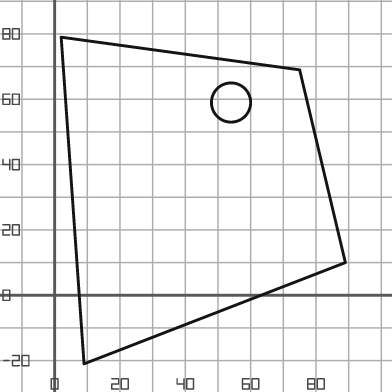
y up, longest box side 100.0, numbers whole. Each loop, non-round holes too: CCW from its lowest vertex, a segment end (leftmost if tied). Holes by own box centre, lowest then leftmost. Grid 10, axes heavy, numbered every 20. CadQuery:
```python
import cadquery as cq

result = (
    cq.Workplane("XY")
    .moveTo(9.0, -21.0)
    .lineTo(89.0, 10.0)
    .lineTo(75.0, 69.0)
    .lineTo(2.0, 79.0)
    .close()
    .moveTo(54.0, 59.0)
    .circle(6.0)
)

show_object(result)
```